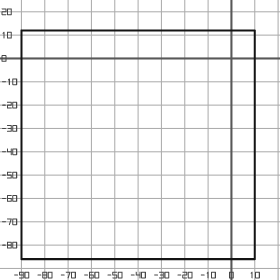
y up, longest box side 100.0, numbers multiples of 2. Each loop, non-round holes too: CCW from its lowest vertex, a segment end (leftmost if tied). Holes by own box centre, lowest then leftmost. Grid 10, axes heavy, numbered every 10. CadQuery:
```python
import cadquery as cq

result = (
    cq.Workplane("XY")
    .moveTo(-90.0, -86.0)
    .lineTo(10.0, -86.0)
    .lineTo(10.0, 12.0)
    .lineTo(-90.0, 12.0)
    .close()
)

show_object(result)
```